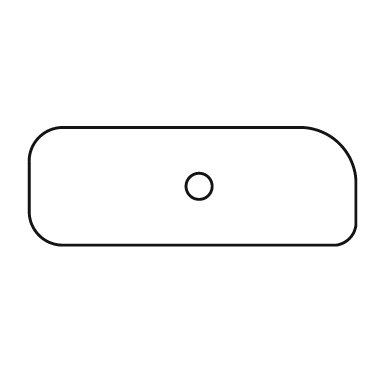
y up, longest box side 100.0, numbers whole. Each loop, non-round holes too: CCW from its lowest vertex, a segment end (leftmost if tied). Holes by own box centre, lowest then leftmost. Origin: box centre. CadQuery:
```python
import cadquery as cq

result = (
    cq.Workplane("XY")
    .moveTo(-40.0, -18.0)
    .lineTo(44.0, -18.0)
    .threePointArc((48.0, -16.0), (50.0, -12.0))
    .lineTo(50.0, 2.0)
    .threePointArc((45.0, 13.0), (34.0, 18.0))
    .lineTo(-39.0, 18.0)
    .threePointArc((-47.0, 15.0), (-50.0, 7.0))
    .lineTo(-50.0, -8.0)
    .threePointArc((-47.0, -15.0), (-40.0, -18.0))
    .close()
    .moveTo(2.0, 0.0)
    .circle(4.0)
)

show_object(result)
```